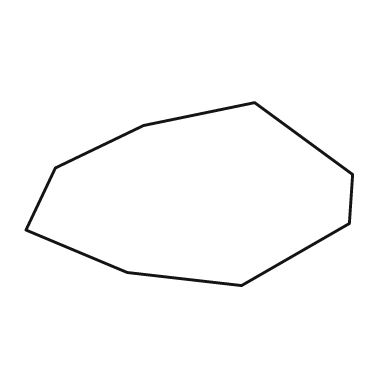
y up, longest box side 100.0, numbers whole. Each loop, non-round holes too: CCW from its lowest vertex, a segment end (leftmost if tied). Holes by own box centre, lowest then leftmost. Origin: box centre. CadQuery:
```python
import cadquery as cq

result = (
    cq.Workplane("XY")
    .moveTo(16.0, -28.0)
    .lineTo(49.0, -9.0)
    .lineTo(50.0, 6.0)
    .lineTo(20.0, 28.0)
    .lineTo(-14.0, 21.0)
    .lineTo(-41.0, 8.0)
    .lineTo(-50.0, -11.0)
    .lineTo(-19.0, -24.0)
    .close()
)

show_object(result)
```